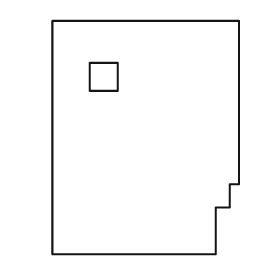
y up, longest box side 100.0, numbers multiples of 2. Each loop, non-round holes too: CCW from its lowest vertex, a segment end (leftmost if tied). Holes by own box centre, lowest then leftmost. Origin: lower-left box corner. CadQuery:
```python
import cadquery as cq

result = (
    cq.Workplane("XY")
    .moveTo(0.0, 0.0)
    .lineTo(70.0, 0.0)
    .lineTo(70.0, 20.0)
    .lineTo(76.0, 20.0)
    .lineTo(76.0, 30.0)
    .lineTo(80.0, 30.0)
    .lineTo(80.0, 100.0)
    .lineTo(0.0, 100.0)
    .close()
    .moveTo(16.0, 70.0)
    .lineTo(28.0, 70.0)
    .lineTo(28.0, 82.0)
    .lineTo(16.0, 82.0)
    .close()
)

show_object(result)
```